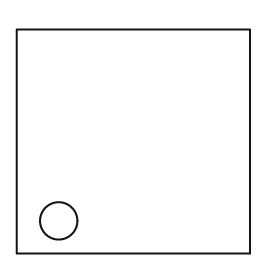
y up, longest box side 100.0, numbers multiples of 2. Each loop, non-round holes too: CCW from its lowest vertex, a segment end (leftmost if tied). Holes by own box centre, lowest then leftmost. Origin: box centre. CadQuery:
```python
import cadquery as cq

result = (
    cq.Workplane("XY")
    .moveTo(-50.0, -48.0)
    .lineTo(50.0, -48.0)
    .lineTo(50.0, 48.0)
    .lineTo(-50.0, 48.0)
    .close()
    .moveTo(-32.0, -34.0)
    .circle(8.0)
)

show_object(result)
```